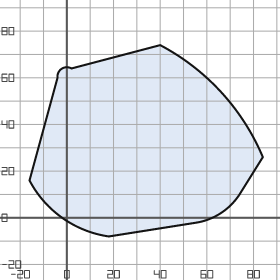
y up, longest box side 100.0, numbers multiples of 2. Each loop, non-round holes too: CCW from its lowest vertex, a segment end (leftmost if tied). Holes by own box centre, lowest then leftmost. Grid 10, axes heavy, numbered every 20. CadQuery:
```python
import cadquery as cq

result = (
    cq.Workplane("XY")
    .moveTo(18.0, -8.0)
    .lineTo(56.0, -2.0)
    .threePointArc((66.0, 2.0), (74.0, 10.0))
    .lineTo(84.0, 26.0)
    .threePointArc((66.0, 54.0), (40.0, 74.0))
    .lineTo(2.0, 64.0)
    .threePointArc((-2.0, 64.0), (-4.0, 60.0))
    .lineTo(-16.0, 16.0)
    .threePointArc((-2.0, 0.0), (18.0, -8.0))
    .close()
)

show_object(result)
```